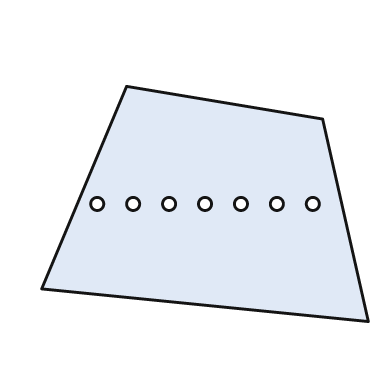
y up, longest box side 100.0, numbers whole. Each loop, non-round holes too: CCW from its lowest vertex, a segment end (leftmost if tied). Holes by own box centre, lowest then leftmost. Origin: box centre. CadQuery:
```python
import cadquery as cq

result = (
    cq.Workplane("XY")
    .moveTo(50.0, -36.0)
    .lineTo(36.0, 26.0)
    .lineTo(-24.0, 36.0)
    .lineTo(-50.0, -26.0)
    .close()
    .moveTo(-33.0, 0.0)
    .circle(2.0)
    .moveTo(-22.0, 0.0)
    .circle(2.0)
    .moveTo(-11.0, 0.0)
    .circle(2.0)
    .moveTo(0.0, 0.0)
    .circle(2.0)
    .moveTo(11.0, 0.0)
    .circle(2.0)
    .moveTo(22.0, 0.0)
    .circle(2.0)
    .moveTo(33.0, 0.0)
    .circle(2.0)
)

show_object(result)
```